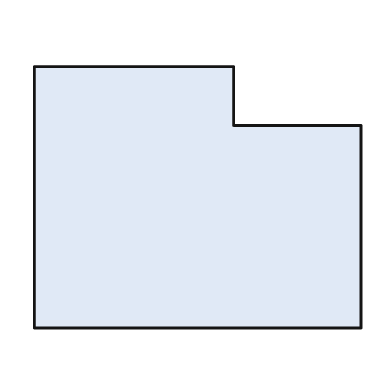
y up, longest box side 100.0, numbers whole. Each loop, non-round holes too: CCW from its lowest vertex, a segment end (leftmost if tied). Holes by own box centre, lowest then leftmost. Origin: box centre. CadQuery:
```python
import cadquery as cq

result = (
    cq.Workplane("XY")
    .moveTo(-50.0, -40.0)
    .lineTo(50.0, -40.0)
    .lineTo(50.0, 22.0)
    .lineTo(11.0, 22.0)
    .lineTo(11.0, 40.0)
    .lineTo(-50.0, 40.0)
    .close()
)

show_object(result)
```